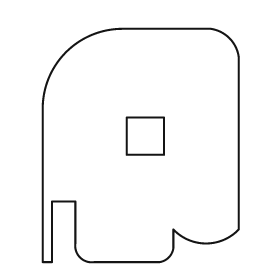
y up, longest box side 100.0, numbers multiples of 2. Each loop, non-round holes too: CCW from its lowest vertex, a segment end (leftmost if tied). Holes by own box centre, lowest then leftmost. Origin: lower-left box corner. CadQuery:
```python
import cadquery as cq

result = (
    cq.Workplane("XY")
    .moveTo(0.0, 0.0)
    .lineTo(4.0, 0.0)
    .lineTo(4.0, 26.0)
    .lineTo(14.0, 26.0)
    .lineTo(14.0, 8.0)
    .threePointArc((16.0, 2.0), (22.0, 0.0))
    .lineTo(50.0, 0.0)
    .threePointArc((54.0, 2.0), (56.0, 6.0))
    .lineTo(56.0, 14.0)
    .threePointArc((70.0, 8.0), (84.0, 14.0))
    .lineTo(84.0, 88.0)
    .threePointArc((80.0, 96.0), (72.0, 100.0))
    .lineTo(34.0, 100.0)
    .threePointArc((10.0, 90.0), (0.0, 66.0))
    .close()
    .moveTo(36.0, 46.0)
    .lineTo(52.0, 46.0)
    .lineTo(52.0, 62.0)
    .lineTo(36.0, 62.0)
    .close()
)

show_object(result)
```